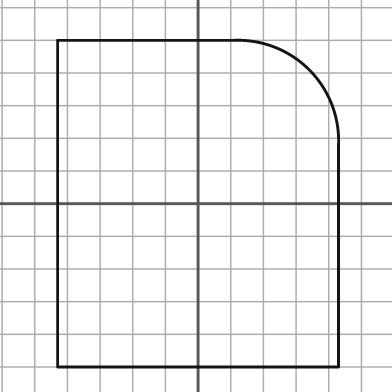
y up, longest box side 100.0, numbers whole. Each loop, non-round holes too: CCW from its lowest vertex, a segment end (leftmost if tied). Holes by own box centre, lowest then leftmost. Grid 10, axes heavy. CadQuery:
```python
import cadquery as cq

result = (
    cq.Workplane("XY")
    .moveTo(-43.0, -50.0)
    .lineTo(43.0, -50.0)
    .lineTo(43.0, 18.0)
    .threePointArc((34.0, 41.0), (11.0, 50.0))
    .lineTo(-43.0, 50.0)
    .close()
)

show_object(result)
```